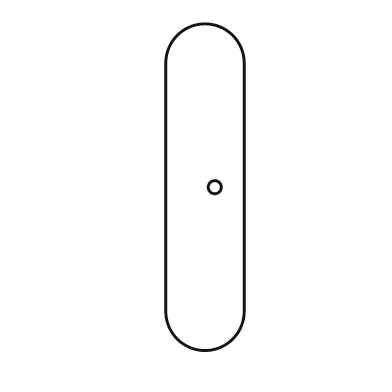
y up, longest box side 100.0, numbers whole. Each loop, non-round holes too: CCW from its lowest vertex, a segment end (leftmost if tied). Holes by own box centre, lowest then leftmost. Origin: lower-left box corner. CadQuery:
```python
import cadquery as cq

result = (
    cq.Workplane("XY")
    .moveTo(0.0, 12.0)
    .threePointArc((12.0, 0.0), (24.0, 12.0))
    .lineTo(24.0, 88.0)
    .threePointArc((12.0, 100.0), (0.0, 88.0))
    .close()
    .moveTo(15.0, 50.0)
    .circle(2.0)
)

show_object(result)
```